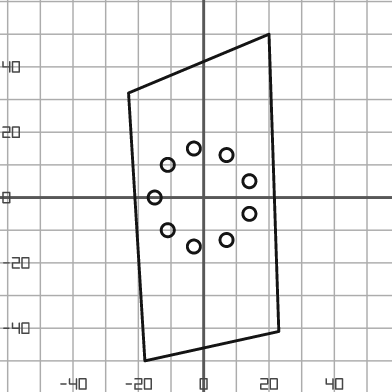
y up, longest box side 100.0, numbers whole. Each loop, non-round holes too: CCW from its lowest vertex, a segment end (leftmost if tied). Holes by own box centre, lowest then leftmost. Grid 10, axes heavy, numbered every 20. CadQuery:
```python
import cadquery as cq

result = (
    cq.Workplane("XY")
    .moveTo(-18.0, -50.0)
    .lineTo(23.0, -41.0)
    .lineTo(20.0, 50.0)
    .lineTo(-23.0, 32.0)
    .close()
    .moveTo(-3.0, -15.0)
    .circle(2.0)
    .moveTo(7.0, -13.0)
    .circle(2.0)
    .moveTo(-11.0, -10.0)
    .circle(2.0)
    .moveTo(14.0, -5.0)
    .circle(2.0)
    .moveTo(-15.0, 0.0)
    .circle(2.0)
    .moveTo(14.0, 5.0)
    .circle(2.0)
    .moveTo(-11.0, 10.0)
    .circle(2.0)
    .moveTo(7.0, 13.0)
    .circle(2.0)
    .moveTo(-3.0, 15.0)
    .circle(2.0)
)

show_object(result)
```